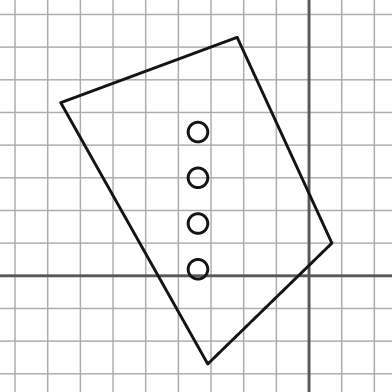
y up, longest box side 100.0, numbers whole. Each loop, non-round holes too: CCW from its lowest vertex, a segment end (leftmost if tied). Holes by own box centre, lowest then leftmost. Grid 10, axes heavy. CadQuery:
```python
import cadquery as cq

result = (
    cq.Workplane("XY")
    .moveTo(-31.0, -27.0)
    .lineTo(7.0, 10.0)
    .lineTo(-22.0, 73.0)
    .lineTo(-76.0, 53.0)
    .close()
    .moveTo(-34.0, 2.0)
    .circle(3.0)
    .moveTo(-34.0, 16.0)
    .circle(3.0)
    .moveTo(-34.0, 30.0)
    .circle(3.0)
    .moveTo(-34.0, 44.0)
    .circle(3.0)
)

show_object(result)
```